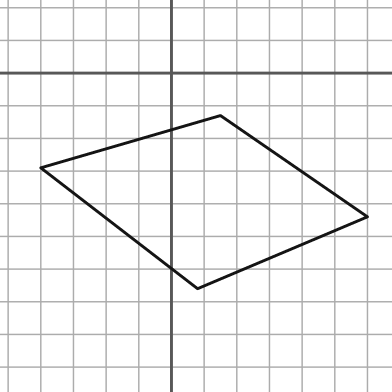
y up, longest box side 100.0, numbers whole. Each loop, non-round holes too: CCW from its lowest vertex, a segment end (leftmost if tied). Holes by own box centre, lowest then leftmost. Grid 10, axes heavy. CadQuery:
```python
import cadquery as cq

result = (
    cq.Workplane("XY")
    .moveTo(8.0, -66.0)
    .lineTo(60.0, -44.0)
    .lineTo(15.0, -13.0)
    .lineTo(-40.0, -29.0)
    .close()
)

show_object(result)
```